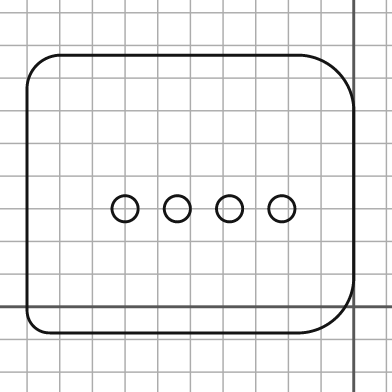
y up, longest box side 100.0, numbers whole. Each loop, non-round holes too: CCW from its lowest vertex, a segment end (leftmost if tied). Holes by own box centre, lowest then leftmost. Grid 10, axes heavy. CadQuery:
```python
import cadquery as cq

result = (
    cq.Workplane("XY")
    .moveTo(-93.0, -8.0)
    .lineTo(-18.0, -8.0)
    .threePointArc((-5.0, -3.0), (0.0, 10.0))
    .lineTo(0.0, 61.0)
    .threePointArc((-5.0, 72.0), (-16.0, 77.0))
    .lineTo(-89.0, 77.0)
    .threePointArc((-97.0, 74.0), (-100.0, 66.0))
    .lineTo(-100.0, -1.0)
    .threePointArc((-98.0, -6.0), (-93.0, -8.0))
    .close()
    .moveTo(-70.0, 30.0)
    .circle(4.0)
    .moveTo(-54.0, 30.0)
    .circle(4.0)
    .moveTo(-38.0, 30.0)
    .circle(4.0)
    .moveTo(-22.0, 30.0)
    .circle(4.0)
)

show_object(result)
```